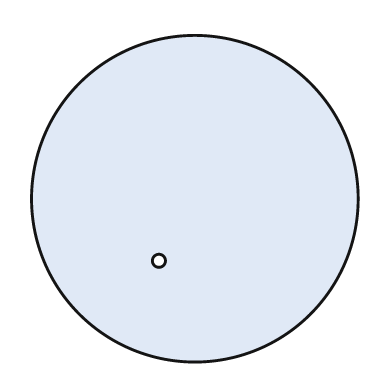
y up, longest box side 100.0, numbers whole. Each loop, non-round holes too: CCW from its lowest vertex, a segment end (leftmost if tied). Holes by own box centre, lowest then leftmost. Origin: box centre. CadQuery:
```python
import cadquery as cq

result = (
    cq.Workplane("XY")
    .moveTo(0.0, 0.0)
    .circle(50.0)
    .moveTo(-11.0, -19.0)
    .circle(2.0)
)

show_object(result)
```